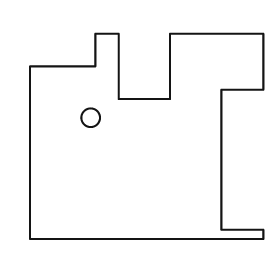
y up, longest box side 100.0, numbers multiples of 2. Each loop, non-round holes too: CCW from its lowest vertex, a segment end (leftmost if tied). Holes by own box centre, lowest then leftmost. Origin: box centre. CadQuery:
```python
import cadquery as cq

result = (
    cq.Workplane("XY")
    .moveTo(-50.0, -44.0)
    .lineTo(50.0, -44.0)
    .lineTo(50.0, -40.0)
    .lineTo(32.0, -40.0)
    .lineTo(32.0, 20.0)
    .lineTo(50.0, 20.0)
    .lineTo(50.0, 44.0)
    .lineTo(10.0, 44.0)
    .lineTo(10.0, 16.0)
    .lineTo(-12.0, 16.0)
    .lineTo(-12.0, 44.0)
    .lineTo(-22.0, 44.0)
    .lineTo(-22.0, 30.0)
    .lineTo(-50.0, 30.0)
    .close()
    .moveTo(-24.0, 8.0)
    .circle(4.0)
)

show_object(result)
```